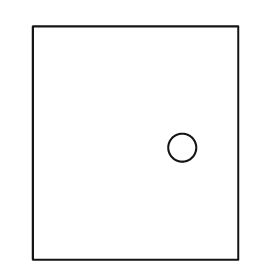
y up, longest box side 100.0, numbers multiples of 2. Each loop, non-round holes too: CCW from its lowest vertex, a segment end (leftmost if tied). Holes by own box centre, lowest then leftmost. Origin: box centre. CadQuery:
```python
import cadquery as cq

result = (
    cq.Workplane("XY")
    .moveTo(-44.0, -50.0)
    .lineTo(44.0, -50.0)
    .lineTo(44.0, 50.0)
    .lineTo(-44.0, 50.0)
    .close()
    .moveTo(20.0, -2.0)
    .circle(6.0)
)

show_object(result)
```